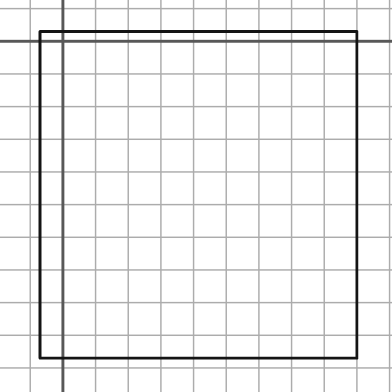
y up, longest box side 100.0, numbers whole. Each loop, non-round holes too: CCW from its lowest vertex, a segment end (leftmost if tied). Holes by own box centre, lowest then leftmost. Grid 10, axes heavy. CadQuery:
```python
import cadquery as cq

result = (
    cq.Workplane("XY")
    .moveTo(-7.0, -97.0)
    .lineTo(90.0, -97.0)
    .lineTo(90.0, 3.0)
    .lineTo(-7.0, 3.0)
    .close()
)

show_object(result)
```